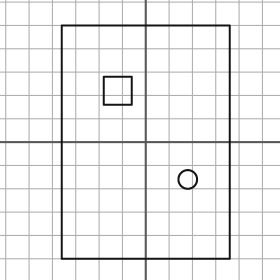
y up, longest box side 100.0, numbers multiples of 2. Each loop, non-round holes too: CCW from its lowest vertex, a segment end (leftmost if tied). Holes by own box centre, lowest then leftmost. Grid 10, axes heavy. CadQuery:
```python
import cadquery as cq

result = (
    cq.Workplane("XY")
    .moveTo(-36.0, -50.0)
    .lineTo(36.0, -50.0)
    .lineTo(36.0, 50.0)
    .lineTo(-36.0, 50.0)
    .close()
    .moveTo(18.0, -16.0)
    .circle(4.0)
    .moveTo(-18.0, 16.0)
    .lineTo(-6.0, 16.0)
    .lineTo(-6.0, 28.0)
    .lineTo(-18.0, 28.0)
    .close()
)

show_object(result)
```